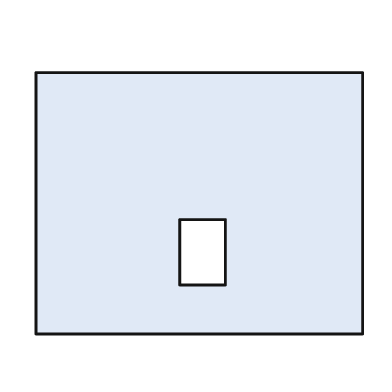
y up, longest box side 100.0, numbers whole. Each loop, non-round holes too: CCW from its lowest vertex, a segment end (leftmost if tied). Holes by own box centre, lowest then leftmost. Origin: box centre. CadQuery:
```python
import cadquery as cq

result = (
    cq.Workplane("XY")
    .moveTo(-50.0, -40.0)
    .lineTo(50.0, -40.0)
    .lineTo(50.0, 40.0)
    .lineTo(-50.0, 40.0)
    .close()
    .moveTo(-6.0, -25.0)
    .lineTo(8.0, -25.0)
    .lineTo(8.0, -5.0)
    .lineTo(-6.0, -5.0)
    .close()
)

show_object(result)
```